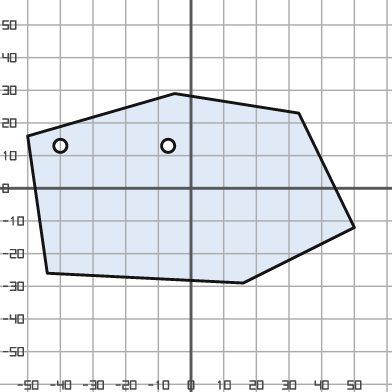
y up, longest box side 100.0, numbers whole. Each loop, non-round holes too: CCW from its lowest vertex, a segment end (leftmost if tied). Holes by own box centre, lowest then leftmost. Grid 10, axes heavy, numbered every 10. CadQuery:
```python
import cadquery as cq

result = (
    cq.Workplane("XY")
    .moveTo(16.0, -29.0)
    .lineTo(50.0, -12.0)
    .lineTo(33.0, 23.0)
    .lineTo(-5.0, 29.0)
    .lineTo(-50.0, 16.0)
    .lineTo(-44.0, -26.0)
    .close()
    .moveTo(-40.0, 13.0)
    .circle(2.0)
    .moveTo(-7.0, 13.0)
    .circle(2.0)
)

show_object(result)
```